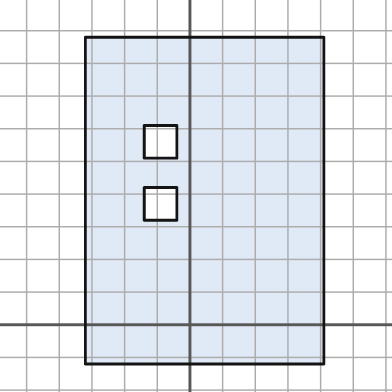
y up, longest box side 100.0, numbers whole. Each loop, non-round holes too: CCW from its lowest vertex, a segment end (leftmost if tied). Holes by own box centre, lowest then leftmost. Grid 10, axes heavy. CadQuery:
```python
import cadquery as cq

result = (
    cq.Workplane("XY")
    .moveTo(-32.0, -12.0)
    .lineTo(41.0, -12.0)
    .lineTo(41.0, 88.0)
    .lineTo(-32.0, 88.0)
    .close()
    .moveTo(-14.0, 32.0)
    .lineTo(-4.0, 32.0)
    .lineTo(-4.0, 42.0)
    .lineTo(-14.0, 42.0)
    .close()
    .moveTo(-14.0, 51.0)
    .lineTo(-4.0, 51.0)
    .lineTo(-4.0, 61.0)
    .lineTo(-14.0, 61.0)
    .close()
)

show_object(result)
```